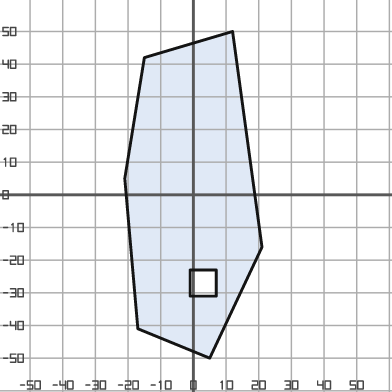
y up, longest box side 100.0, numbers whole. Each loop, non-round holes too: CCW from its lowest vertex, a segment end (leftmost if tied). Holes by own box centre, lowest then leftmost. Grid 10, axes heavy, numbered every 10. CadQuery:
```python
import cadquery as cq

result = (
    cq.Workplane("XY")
    .moveTo(5.0, -50.0)
    .lineTo(21.0, -16.0)
    .lineTo(12.0, 50.0)
    .lineTo(-15.0, 42.0)
    .lineTo(-21.0, 5.0)
    .lineTo(-17.0, -41.0)
    .close()
    .moveTo(-1.0, -31.0)
    .lineTo(7.0, -31.0)
    .lineTo(7.0, -23.0)
    .lineTo(-1.0, -23.0)
    .close()
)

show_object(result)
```